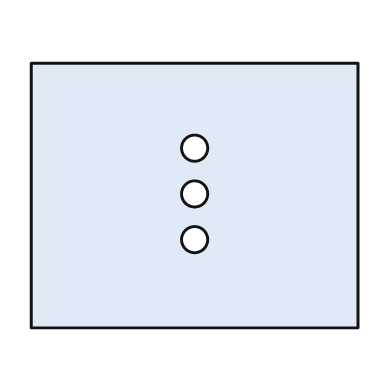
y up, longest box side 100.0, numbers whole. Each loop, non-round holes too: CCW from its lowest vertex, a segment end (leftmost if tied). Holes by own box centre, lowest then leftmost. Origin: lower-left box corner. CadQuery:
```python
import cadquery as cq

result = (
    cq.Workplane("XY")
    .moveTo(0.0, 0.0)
    .lineTo(100.0, 0.0)
    .lineTo(100.0, 81.0)
    .lineTo(0.0, 81.0)
    .close()
    .moveTo(50.0, 27.0)
    .circle(4.0)
    .moveTo(50.0, 41.0)
    .circle(4.0)
    .moveTo(50.0, 55.0)
    .circle(4.0)
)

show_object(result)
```